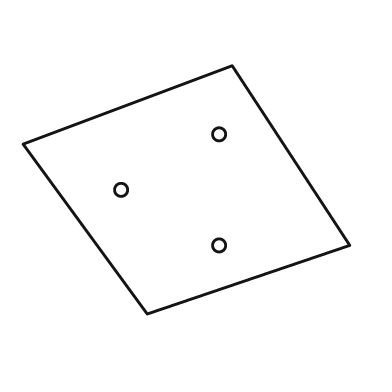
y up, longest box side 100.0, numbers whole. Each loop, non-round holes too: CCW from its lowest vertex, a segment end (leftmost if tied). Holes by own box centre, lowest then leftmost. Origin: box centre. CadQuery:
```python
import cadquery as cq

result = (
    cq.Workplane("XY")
    .moveTo(-12.0, -38.0)
    .lineTo(50.0, -17.0)
    .lineTo(14.0, 38.0)
    .lineTo(-50.0, 14.0)
    .close()
    .moveTo(10.0, -17.0)
    .circle(2.0)
    .moveTo(-20.0, 0.0)
    .circle(2.0)
    .moveTo(10.0, 17.0)
    .circle(2.0)
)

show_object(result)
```